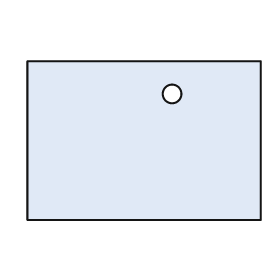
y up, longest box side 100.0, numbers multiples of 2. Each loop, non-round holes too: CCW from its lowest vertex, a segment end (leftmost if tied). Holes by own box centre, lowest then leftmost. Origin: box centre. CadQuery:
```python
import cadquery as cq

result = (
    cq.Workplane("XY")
    .moveTo(-50.0, -34.0)
    .lineTo(50.0, -34.0)
    .lineTo(50.0, 34.0)
    .lineTo(-50.0, 34.0)
    .close()
    .moveTo(12.0, 20.0)
    .circle(4.0)
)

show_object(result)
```